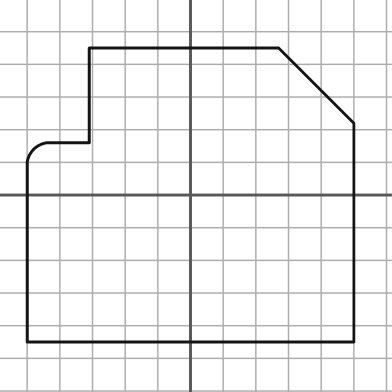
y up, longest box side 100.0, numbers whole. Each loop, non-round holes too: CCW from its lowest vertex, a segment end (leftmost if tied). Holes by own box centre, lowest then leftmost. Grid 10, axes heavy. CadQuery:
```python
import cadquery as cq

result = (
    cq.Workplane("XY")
    .moveTo(-50.0, -45.0)
    .lineTo(50.0, -45.0)
    .lineTo(50.0, 22.0)
    .lineTo(27.0, 45.0)
    .lineTo(-31.0, 45.0)
    .lineTo(-31.0, 16.0)
    .lineTo(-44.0, 16.0)
    .threePointArc((-48.0, 14.0), (-50.0, 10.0))
    .close()
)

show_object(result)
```